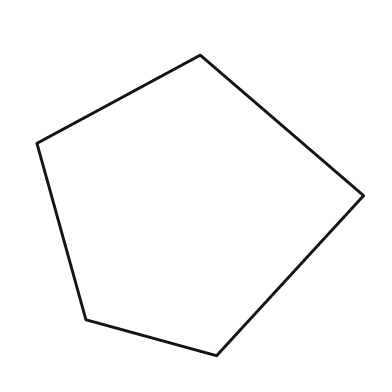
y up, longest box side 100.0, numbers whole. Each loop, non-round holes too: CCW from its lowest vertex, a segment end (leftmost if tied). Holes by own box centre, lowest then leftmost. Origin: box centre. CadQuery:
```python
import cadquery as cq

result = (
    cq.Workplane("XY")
    .moveTo(5.0, -46.0)
    .lineTo(50.0, 3.0)
    .lineTo(0.0, 46.0)
    .lineTo(-50.0, 19.0)
    .lineTo(-35.0, -35.0)
    .close()
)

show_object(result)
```